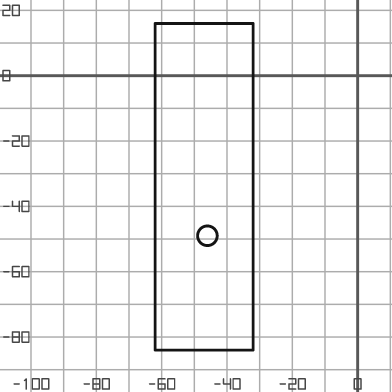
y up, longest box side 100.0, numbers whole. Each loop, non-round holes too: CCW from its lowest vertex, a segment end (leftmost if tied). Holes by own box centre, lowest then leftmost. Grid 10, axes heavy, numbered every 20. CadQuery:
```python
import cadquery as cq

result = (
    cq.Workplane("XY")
    .moveTo(-62.0, -84.0)
    .lineTo(-32.0, -84.0)
    .lineTo(-32.0, 16.0)
    .lineTo(-62.0, 16.0)
    .close()
    .moveTo(-46.0, -49.0)
    .circle(3.0)
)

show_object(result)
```